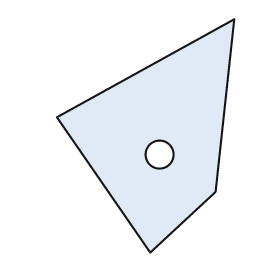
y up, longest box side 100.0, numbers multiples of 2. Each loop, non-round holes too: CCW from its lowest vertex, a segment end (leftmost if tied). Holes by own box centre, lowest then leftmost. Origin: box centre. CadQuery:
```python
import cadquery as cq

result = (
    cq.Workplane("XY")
    .moveTo(2.0, -50.0)
    .lineTo(30.0, -24.0)
    .lineTo(38.0, 50.0)
    .lineTo(-38.0, 8.0)
    .close()
    .moveTo(6.0, -8.0)
    .circle(6.0)
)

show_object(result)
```